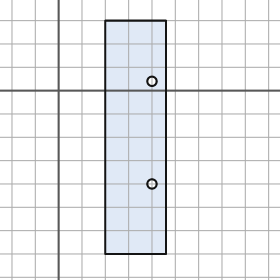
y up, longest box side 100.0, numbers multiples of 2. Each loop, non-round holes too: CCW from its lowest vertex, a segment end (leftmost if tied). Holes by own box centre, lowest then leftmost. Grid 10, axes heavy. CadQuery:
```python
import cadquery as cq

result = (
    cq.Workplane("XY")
    .moveTo(20.0, -70.0)
    .lineTo(46.0, -70.0)
    .lineTo(46.0, 30.0)
    .lineTo(20.0, 30.0)
    .close()
    .moveTo(40.0, -40.0)
    .circle(2.0)
    .moveTo(40.0, 4.0)
    .circle(2.0)
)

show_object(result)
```